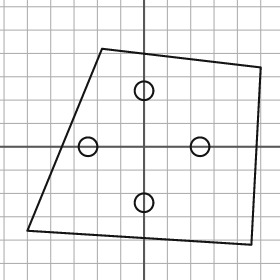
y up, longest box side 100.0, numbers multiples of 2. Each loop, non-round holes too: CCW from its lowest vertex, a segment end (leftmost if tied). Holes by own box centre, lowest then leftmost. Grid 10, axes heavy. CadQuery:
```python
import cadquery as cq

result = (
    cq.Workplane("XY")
    .moveTo(46.0, -42.0)
    .lineTo(50.0, 34.0)
    .lineTo(-18.0, 42.0)
    .lineTo(-50.0, -36.0)
    .close()
    .moveTo(0.0, -24.0)
    .circle(4.0)
    .moveTo(-24.0, 0.0)
    .circle(4.0)
    .moveTo(24.0, 0.0)
    .circle(4.0)
    .moveTo(0.0, 24.0)
    .circle(4.0)
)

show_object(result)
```